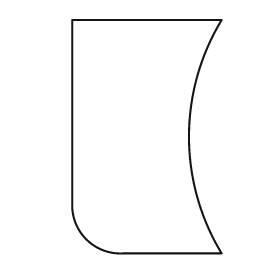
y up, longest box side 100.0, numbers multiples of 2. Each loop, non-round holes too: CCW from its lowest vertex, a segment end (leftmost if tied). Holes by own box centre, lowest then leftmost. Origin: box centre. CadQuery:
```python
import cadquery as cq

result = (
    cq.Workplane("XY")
    .moveTo(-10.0, -50.0)
    .lineTo(32.0, -50.0)
    .threePointArc((18.0, 0.0), (32.0, 50.0))
    .lineTo(-32.0, 50.0)
    .lineTo(-32.0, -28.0)
    .threePointArc((-26.0, -44.0), (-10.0, -50.0))
    .close()
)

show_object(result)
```